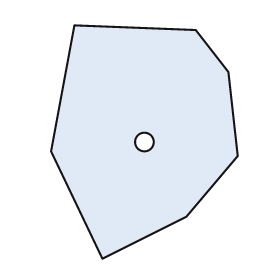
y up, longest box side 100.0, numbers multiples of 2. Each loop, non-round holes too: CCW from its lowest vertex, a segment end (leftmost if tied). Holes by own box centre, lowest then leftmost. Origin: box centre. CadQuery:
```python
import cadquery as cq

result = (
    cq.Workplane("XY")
    .moveTo(-18.0, -50.0)
    .lineTo(18.0, -32.0)
    .lineTo(40.0, -6.0)
    .lineTo(36.0, 30.0)
    .lineTo(22.0, 48.0)
    .lineTo(-30.0, 50.0)
    .lineTo(-40.0, -4.0)
    .close()
    .moveTo(0.0, 0.0)
    .circle(4.0)
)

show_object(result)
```